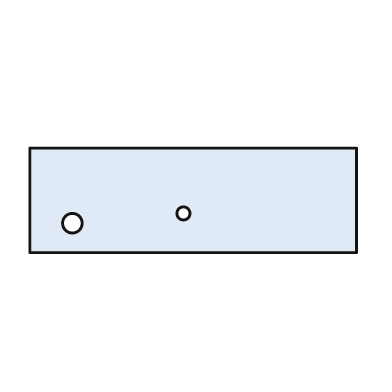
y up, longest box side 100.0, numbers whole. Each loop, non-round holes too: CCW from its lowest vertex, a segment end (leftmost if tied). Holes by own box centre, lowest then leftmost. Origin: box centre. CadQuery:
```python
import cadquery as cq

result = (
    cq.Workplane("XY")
    .moveTo(-50.0, -16.0)
    .lineTo(50.0, -16.0)
    .lineTo(50.0, 16.0)
    .lineTo(-50.0, 16.0)
    .close()
    .moveTo(-37.0, -7.0)
    .circle(3.0)
    .moveTo(-3.0, -4.0)
    .circle(2.0)
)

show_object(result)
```